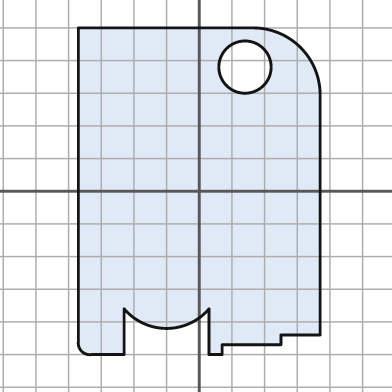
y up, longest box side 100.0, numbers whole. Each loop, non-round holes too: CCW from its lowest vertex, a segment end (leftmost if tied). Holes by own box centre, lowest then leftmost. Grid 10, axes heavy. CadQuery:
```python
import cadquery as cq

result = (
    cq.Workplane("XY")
    .moveTo(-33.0, -50.0)
    .lineTo(-23.0, -50.0)
    .lineTo(-23.0, -36.0)
    .threePointArc((-10.0, -42.0), (3.0, -36.0))
    .lineTo(3.0, -50.0)
    .lineTo(7.0, -50.0)
    .lineTo(7.0, -47.0)
    .lineTo(25.0, -47.0)
    .lineTo(25.0, -44.0)
    .lineTo(37.0, -44.0)
    .lineTo(37.0, 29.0)
    .threePointArc((31.0, 44.0), (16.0, 50.0))
    .lineTo(-37.0, 50.0)
    .lineTo(-37.0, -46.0)
    .threePointArc((-36.0, -49.0), (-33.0, -50.0))
    .close()
    .moveTo(14.0, 38.0)
    .circle(8.0)
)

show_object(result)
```